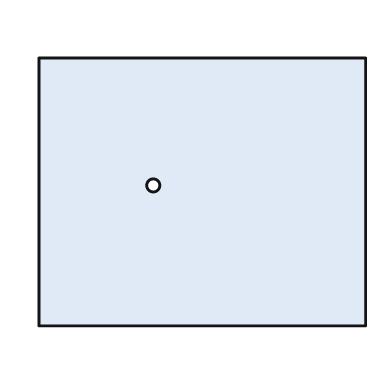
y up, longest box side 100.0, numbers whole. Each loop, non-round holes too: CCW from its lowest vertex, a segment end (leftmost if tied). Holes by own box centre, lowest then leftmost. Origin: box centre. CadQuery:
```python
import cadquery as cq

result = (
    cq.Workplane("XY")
    .moveTo(-50.0, -41.0)
    .lineTo(50.0, -41.0)
    .lineTo(50.0, 41.0)
    .lineTo(-50.0, 41.0)
    .close()
    .moveTo(-15.0, 2.0)
    .circle(2.0)
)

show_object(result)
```